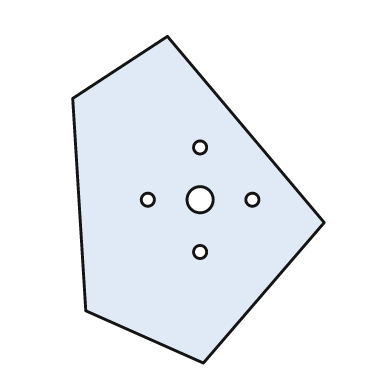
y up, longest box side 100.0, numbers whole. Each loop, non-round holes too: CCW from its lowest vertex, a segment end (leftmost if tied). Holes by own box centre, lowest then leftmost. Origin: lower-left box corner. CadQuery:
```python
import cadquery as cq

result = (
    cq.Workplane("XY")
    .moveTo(40.0, 0.0)
    .lineTo(77.0, 43.0)
    .lineTo(29.0, 100.0)
    .lineTo(0.0, 81.0)
    .lineTo(4.0, 16.0)
    .close()
    .moveTo(39.0, 34.0)
    .circle(2.0)
    .moveTo(23.0, 50.0)
    .circle(2.0)
    .moveTo(39.0, 50.0)
    .circle(4.0)
    .moveTo(55.0, 50.0)
    .circle(2.0)
    .moveTo(39.0, 66.0)
    .circle(2.0)
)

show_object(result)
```